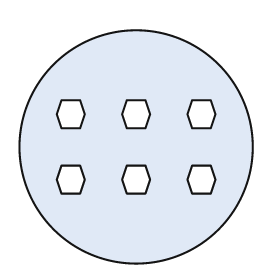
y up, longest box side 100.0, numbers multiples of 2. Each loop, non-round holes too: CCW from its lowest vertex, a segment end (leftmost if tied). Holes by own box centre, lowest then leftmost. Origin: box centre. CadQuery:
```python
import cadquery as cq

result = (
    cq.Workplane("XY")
    .moveTo(0.0, 0.0)
    .circle(50.0)
    .moveTo(-32.0, -20.0)
    .lineTo(-24.0, -20.0)
    .lineTo(-22.0, -14.0)
    .lineTo(-24.0, -8.0)
    .lineTo(-32.0, -8.0)
    .lineTo(-34.0, -14.0)
    .close()
    .moveTo(-4.0, -20.0)
    .lineTo(4.0, -20.0)
    .lineTo(6.0, -14.0)
    .lineTo(4.0, -8.0)
    .lineTo(-4.0, -8.0)
    .lineTo(-6.0, -14.0)
    .close()
    .moveTo(24.0, -20.0)
    .lineTo(32.0, -20.0)
    .lineTo(34.0, -14.0)
    .lineTo(32.0, -8.0)
    .lineTo(24.0, -8.0)
    .lineTo(22.0, -14.0)
    .close()
    .moveTo(-32.0, 8.0)
    .lineTo(-24.0, 8.0)
    .lineTo(-22.0, 14.0)
    .lineTo(-24.0, 20.0)
    .lineTo(-32.0, 20.0)
    .lineTo(-34.0, 14.0)
    .close()
    .moveTo(-4.0, 8.0)
    .lineTo(4.0, 8.0)
    .lineTo(6.0, 14.0)
    .lineTo(4.0, 20.0)
    .lineTo(-4.0, 20.0)
    .lineTo(-6.0, 14.0)
    .close()
    .moveTo(24.0, 8.0)
    .lineTo(32.0, 8.0)
    .lineTo(34.0, 14.0)
    .lineTo(32.0, 20.0)
    .lineTo(24.0, 20.0)
    .lineTo(22.0, 14.0)
    .close()
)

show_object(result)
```